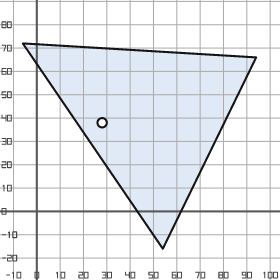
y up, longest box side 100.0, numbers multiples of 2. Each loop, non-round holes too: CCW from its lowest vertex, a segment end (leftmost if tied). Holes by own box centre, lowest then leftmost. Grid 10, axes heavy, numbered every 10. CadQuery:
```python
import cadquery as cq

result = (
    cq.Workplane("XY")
    .moveTo(54.0, -16.0)
    .lineTo(94.0, 66.0)
    .lineTo(-6.0, 72.0)
    .close()
    .moveTo(28.0, 38.0)
    .circle(2.0)
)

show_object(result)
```